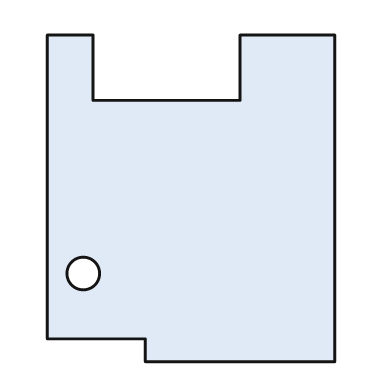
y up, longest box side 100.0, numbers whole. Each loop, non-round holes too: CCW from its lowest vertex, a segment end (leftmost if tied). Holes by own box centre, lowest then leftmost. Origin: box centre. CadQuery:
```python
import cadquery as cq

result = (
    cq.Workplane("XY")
    .moveTo(-14.0, -50.0)
    .lineTo(44.0, -50.0)
    .lineTo(44.0, 50.0)
    .lineTo(15.0, 50.0)
    .lineTo(15.0, 30.0)
    .lineTo(-30.0, 30.0)
    .lineTo(-30.0, 50.0)
    .lineTo(-44.0, 50.0)
    .lineTo(-44.0, -43.0)
    .lineTo(-14.0, -43.0)
    .close()
    .moveTo(-33.0, -23.0)
    .circle(5.0)
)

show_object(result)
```